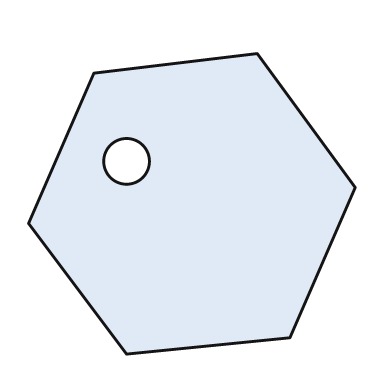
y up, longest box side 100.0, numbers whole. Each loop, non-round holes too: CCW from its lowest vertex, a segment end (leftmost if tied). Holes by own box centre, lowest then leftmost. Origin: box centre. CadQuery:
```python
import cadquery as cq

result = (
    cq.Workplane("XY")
    .moveTo(-20.0, -46.0)
    .lineTo(30.0, -41.0)
    .lineTo(50.0, 5.0)
    .lineTo(20.0, 46.0)
    .lineTo(-30.0, 40.0)
    .lineTo(-50.0, -6.0)
    .close()
    .moveTo(-20.0, 13.0)
    .circle(7.0)
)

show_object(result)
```